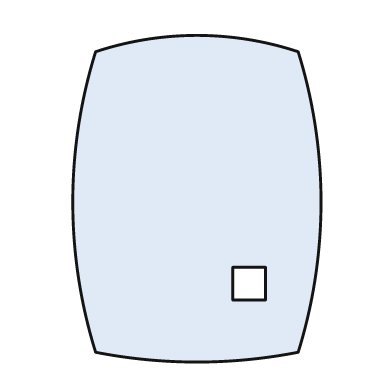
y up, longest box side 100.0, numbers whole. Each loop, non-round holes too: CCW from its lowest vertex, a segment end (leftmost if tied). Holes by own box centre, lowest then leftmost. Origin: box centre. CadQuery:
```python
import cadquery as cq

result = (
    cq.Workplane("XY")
    .moveTo(-31.0, -47.0)
    .threePointArc((0.0, -50.0), (31.0, -47.0))
    .threePointArc((38.0, -1.0), (31.0, 45.0))
    .threePointArc((0.0, 50.0), (-31.0, 45.0))
    .threePointArc((-38.0, -1.0), (-31.0, -47.0))
    .close()
    .moveTo(11.0, -31.0)
    .lineTo(21.0, -31.0)
    .lineTo(21.0, -21.0)
    .lineTo(11.0, -21.0)
    .close()
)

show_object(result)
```